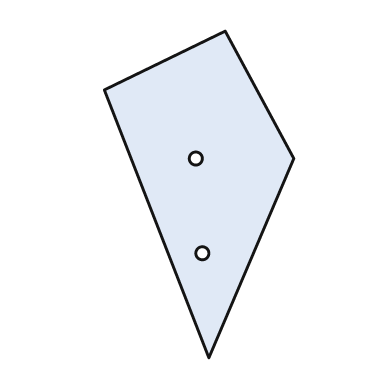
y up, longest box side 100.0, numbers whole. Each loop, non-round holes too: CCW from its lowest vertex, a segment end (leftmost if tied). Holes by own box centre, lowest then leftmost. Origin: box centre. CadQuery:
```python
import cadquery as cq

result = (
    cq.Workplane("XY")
    .moveTo(3.0, -50.0)
    .lineTo(29.0, 11.0)
    .lineTo(8.0, 50.0)
    .lineTo(-29.0, 32.0)
    .close()
    .moveTo(1.0, -18.0)
    .circle(2.0)
    .moveTo(-1.0, 11.0)
    .circle(2.0)
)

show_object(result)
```